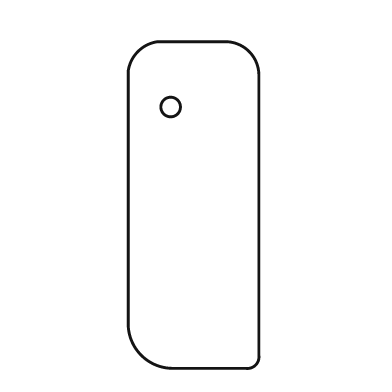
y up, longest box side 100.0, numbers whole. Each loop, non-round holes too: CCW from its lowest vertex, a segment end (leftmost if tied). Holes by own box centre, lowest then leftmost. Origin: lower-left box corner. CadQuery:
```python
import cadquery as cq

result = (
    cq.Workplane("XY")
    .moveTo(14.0, 0.0)
    .lineTo(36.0, 0.0)
    .threePointArc((39.0, 1.0), (40.0, 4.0))
    .lineTo(40.0, 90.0)
    .threePointArc((37.0, 97.0), (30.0, 100.0))
    .lineTo(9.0, 100.0)
    .threePointArc((3.0, 97.0), (0.0, 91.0))
    .lineTo(0.0, 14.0)
    .threePointArc((4.0, 4.0), (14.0, 0.0))
    .close()
    .moveTo(13.0, 80.0)
    .circle(3.0)
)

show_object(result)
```